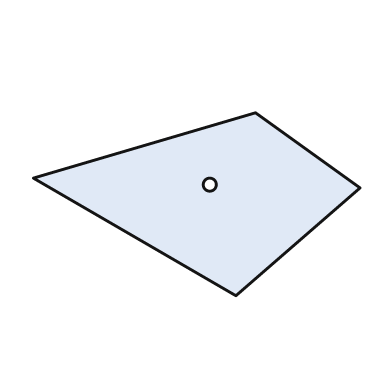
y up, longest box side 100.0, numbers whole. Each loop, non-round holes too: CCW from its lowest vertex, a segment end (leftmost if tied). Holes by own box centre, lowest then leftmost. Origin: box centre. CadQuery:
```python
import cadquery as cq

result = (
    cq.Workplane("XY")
    .moveTo(12.0, -28.0)
    .lineTo(50.0, 5.0)
    .lineTo(18.0, 28.0)
    .lineTo(-50.0, 8.0)
    .close()
    .moveTo(4.0, 6.0)
    .circle(2.0)
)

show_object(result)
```